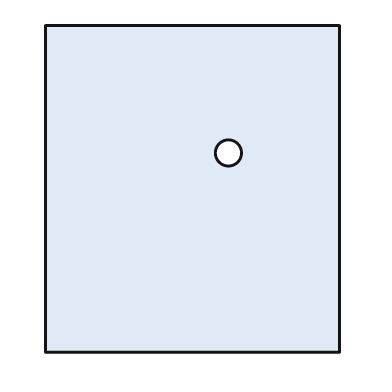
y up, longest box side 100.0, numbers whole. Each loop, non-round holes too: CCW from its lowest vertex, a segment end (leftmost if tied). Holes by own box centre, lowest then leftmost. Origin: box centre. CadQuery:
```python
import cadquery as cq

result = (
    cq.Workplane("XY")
    .moveTo(-45.0, -50.0)
    .lineTo(45.0, -50.0)
    .lineTo(45.0, 50.0)
    .lineTo(-45.0, 50.0)
    .close()
    .moveTo(11.0, 11.0)
    .circle(4.0)
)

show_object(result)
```